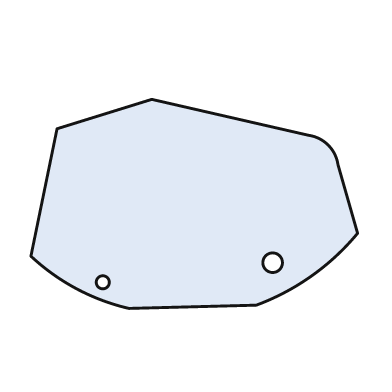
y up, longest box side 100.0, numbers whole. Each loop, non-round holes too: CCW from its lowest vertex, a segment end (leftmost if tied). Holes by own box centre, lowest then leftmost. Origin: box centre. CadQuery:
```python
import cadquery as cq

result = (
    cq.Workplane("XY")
    .moveTo(-20.0, -32.0)
    .lineTo(19.0, -31.0)
    .threePointArc((36.0, -22.0), (50.0, -9.0))
    .lineTo(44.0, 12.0)
    .threePointArc((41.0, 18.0), (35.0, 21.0))
    .lineTo(-13.0, 32.0)
    .lineTo(-42.0, 23.0)
    .lineTo(-50.0, -16.0)
    .threePointArc((-36.0, -26.0), (-20.0, -32.0))
    .close()
    .moveTo(-28.0, -24.0)
    .circle(2.0)
    .moveTo(24.0, -18.0)
    .circle(3.0)
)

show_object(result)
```